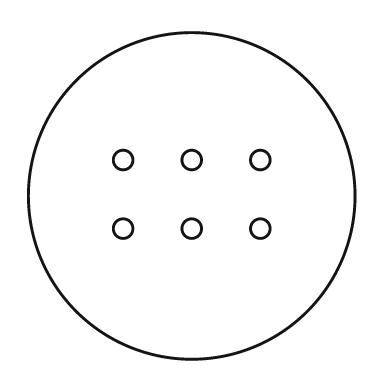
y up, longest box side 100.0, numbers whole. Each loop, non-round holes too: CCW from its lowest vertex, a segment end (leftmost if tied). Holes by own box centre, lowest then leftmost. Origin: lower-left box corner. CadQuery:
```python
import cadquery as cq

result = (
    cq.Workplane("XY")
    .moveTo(50.0, 50.0)
    .circle(50.0)
    .moveTo(29.0, 40.0)
    .circle(3.0)
    .moveTo(50.0, 40.0)
    .circle(3.0)
    .moveTo(71.0, 40.0)
    .circle(3.0)
    .moveTo(29.0, 61.0)
    .circle(3.0)
    .moveTo(50.0, 61.0)
    .circle(3.0)
    .moveTo(71.0, 61.0)
    .circle(3.0)
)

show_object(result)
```